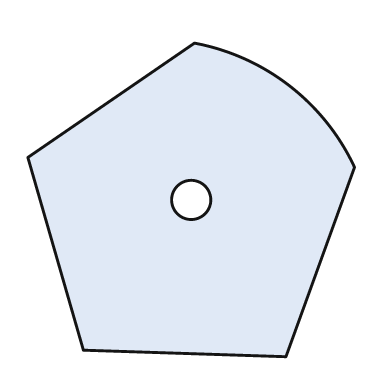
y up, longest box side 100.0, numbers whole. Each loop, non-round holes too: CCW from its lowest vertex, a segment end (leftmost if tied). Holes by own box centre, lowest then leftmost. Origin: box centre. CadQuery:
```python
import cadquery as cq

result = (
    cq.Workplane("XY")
    .moveTo(29.0, -48.0)
    .lineTo(50.0, 10.0)
    .threePointArc((30.0, 35.0), (1.0, 48.0))
    .lineTo(-50.0, 13.0)
    .lineTo(-33.0, -46.0)
    .close()
    .moveTo(0.0, 0.0)
    .circle(6.0)
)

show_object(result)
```